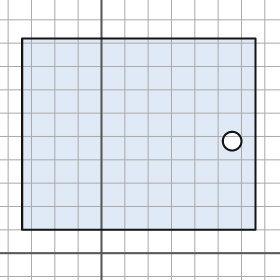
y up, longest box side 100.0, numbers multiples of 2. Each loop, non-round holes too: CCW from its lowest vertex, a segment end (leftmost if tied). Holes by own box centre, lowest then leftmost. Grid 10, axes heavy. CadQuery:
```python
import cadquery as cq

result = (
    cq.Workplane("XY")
    .moveTo(-34.0, 10.0)
    .lineTo(66.0, 10.0)
    .lineTo(66.0, 92.0)
    .lineTo(-34.0, 92.0)
    .close()
    .moveTo(56.0, 48.0)
    .circle(4.0)
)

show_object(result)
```